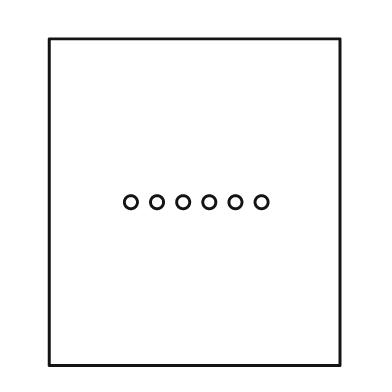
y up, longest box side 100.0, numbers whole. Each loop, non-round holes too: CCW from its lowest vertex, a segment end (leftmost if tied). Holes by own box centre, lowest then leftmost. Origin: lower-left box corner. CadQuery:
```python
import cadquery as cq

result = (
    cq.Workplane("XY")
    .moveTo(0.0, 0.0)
    .lineTo(89.0, 0.0)
    .lineTo(89.0, 100.0)
    .lineTo(0.0, 100.0)
    .close()
    .moveTo(25.0, 50.0)
    .circle(2.0)
    .moveTo(33.0, 50.0)
    .circle(2.0)
    .moveTo(41.0, 50.0)
    .circle(2.0)
    .moveTo(49.0, 50.0)
    .circle(2.0)
    .moveTo(57.0, 50.0)
    .circle(2.0)
    .moveTo(65.0, 50.0)
    .circle(2.0)
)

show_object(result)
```